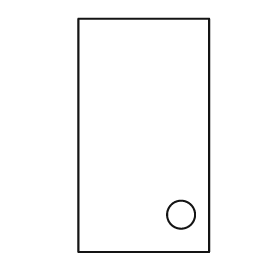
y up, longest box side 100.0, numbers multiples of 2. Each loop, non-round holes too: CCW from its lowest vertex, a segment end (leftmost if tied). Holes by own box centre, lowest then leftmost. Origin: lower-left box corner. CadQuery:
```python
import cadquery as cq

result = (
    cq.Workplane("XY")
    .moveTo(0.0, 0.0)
    .lineTo(56.0, 0.0)
    .lineTo(56.0, 100.0)
    .lineTo(0.0, 100.0)
    .close()
    .moveTo(44.0, 16.0)
    .circle(6.0)
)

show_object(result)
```